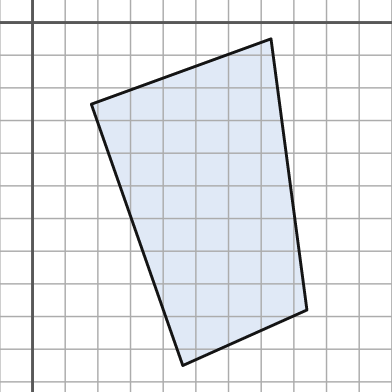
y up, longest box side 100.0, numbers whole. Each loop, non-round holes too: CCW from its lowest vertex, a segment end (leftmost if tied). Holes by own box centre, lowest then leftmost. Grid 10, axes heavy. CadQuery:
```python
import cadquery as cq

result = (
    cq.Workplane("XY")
    .moveTo(46.0, -105.0)
    .lineTo(84.0, -88.0)
    .lineTo(73.0, -5.0)
    .lineTo(18.0, -25.0)
    .close()
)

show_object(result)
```